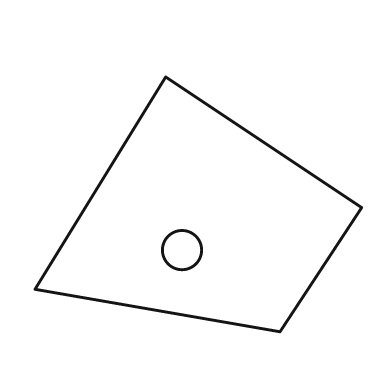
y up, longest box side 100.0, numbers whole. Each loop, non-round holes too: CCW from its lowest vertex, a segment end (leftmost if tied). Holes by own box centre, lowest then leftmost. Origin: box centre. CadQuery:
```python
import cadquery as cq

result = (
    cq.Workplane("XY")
    .moveTo(25.0, -39.0)
    .lineTo(50.0, -1.0)
    .lineTo(-10.0, 39.0)
    .lineTo(-50.0, -26.0)
    .close()
    .moveTo(-5.0, -14.0)
    .circle(6.0)
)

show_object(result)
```